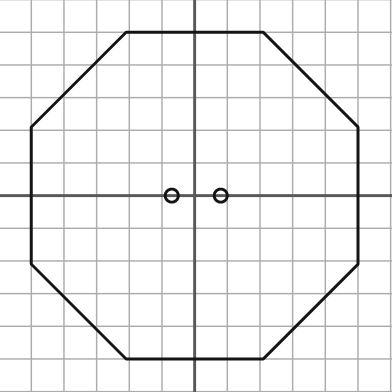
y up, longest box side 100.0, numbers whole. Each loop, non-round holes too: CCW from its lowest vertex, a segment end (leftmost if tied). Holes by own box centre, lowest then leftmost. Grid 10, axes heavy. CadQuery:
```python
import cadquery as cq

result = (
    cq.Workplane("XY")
    .moveTo(-21.0, -50.0)
    .lineTo(21.0, -50.0)
    .lineTo(50.0, -21.0)
    .lineTo(50.0, 21.0)
    .lineTo(21.0, 50.0)
    .lineTo(-21.0, 50.0)
    .lineTo(-50.0, 21.0)
    .lineTo(-50.0, -21.0)
    .close()
    .moveTo(-7.0, 0.0)
    .circle(2.0)
    .moveTo(8.0, 0.0)
    .circle(2.0)
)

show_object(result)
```